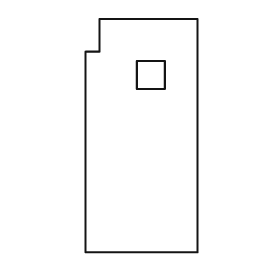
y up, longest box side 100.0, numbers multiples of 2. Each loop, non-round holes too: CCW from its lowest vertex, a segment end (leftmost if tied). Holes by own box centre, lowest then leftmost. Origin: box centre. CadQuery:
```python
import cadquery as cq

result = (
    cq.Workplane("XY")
    .moveTo(-24.0, -50.0)
    .lineTo(24.0, -50.0)
    .lineTo(24.0, 50.0)
    .lineTo(-18.0, 50.0)
    .lineTo(-18.0, 36.0)
    .lineTo(-24.0, 36.0)
    .close()
    .moveTo(-2.0, 20.0)
    .lineTo(10.0, 20.0)
    .lineTo(10.0, 32.0)
    .lineTo(-2.0, 32.0)
    .close()
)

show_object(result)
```